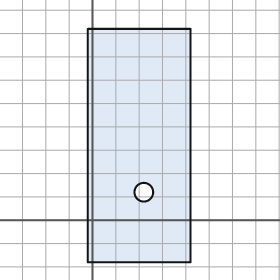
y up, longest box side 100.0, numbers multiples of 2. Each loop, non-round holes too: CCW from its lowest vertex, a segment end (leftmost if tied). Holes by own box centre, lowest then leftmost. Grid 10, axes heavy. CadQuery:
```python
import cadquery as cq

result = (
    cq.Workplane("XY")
    .moveTo(-2.0, -18.0)
    .lineTo(42.0, -18.0)
    .lineTo(42.0, 82.0)
    .lineTo(-2.0, 82.0)
    .close()
    .moveTo(22.0, 12.0)
    .circle(4.0)
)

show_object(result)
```